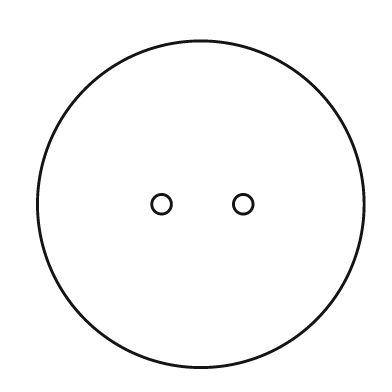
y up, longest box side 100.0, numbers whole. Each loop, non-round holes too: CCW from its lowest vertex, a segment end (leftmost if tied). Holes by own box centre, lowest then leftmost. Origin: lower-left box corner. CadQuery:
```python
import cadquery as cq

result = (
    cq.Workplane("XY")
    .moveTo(50.0, 50.0)
    .circle(50.0)
    .moveTo(38.0, 50.0)
    .circle(3.0)
    .moveTo(63.0, 50.0)
    .circle(3.0)
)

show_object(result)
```